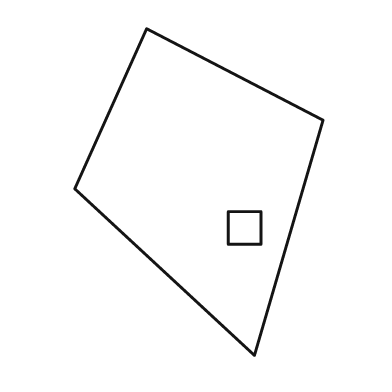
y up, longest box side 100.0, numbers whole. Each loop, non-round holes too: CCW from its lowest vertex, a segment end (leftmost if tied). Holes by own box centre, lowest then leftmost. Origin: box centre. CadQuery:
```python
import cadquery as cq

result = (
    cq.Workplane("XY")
    .moveTo(17.0, -50.0)
    .lineTo(38.0, 22.0)
    .lineTo(-16.0, 50.0)
    .lineTo(-38.0, 1.0)
    .close()
    .moveTo(9.0, -16.0)
    .lineTo(19.0, -16.0)
    .lineTo(19.0, -6.0)
    .lineTo(9.0, -6.0)
    .close()
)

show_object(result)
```